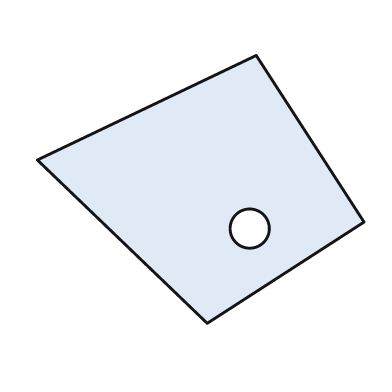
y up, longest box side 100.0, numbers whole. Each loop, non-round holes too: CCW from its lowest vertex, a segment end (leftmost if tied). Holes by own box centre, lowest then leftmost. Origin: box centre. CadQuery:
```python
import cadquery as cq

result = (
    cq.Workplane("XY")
    .moveTo(2.0, -41.0)
    .lineTo(50.0, -10.0)
    .lineTo(17.0, 41.0)
    .lineTo(-50.0, 9.0)
    .close()
    .moveTo(15.0, -12.0)
    .circle(6.0)
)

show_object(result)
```